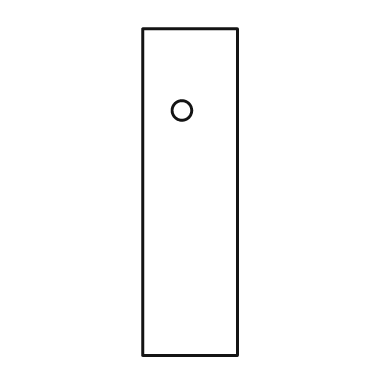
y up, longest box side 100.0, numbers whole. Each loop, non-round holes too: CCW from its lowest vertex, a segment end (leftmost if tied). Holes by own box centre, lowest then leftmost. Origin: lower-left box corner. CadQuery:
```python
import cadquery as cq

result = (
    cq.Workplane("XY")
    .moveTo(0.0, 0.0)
    .lineTo(29.0, 0.0)
    .lineTo(29.0, 100.0)
    .lineTo(0.0, 100.0)
    .close()
    .moveTo(12.0, 75.0)
    .circle(3.0)
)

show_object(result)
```